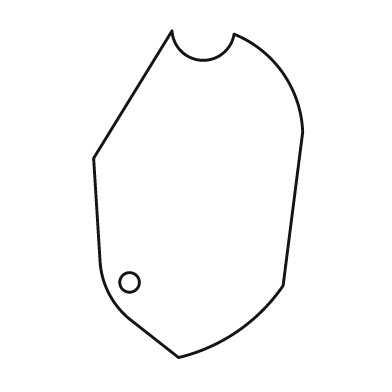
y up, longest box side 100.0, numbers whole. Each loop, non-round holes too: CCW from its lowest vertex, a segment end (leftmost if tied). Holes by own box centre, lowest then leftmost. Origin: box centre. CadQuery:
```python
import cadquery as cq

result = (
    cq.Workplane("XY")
    .moveTo(-6.0, -50.0)
    .threePointArc((12.0, -42.0), (26.0, -28.0))
    .lineTo(32.0, 19.0)
    .threePointArc((26.0, 37.0), (11.0, 49.0))
    .threePointArc((1.0, 41.0), (-8.0, 50.0))
    .lineTo(-32.0, 11.0)
    .lineTo(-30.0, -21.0)
    .threePointArc((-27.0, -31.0), (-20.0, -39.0))
    .close()
    .moveTo(-21.0, -27.0)
    .circle(3.0)
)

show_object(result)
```